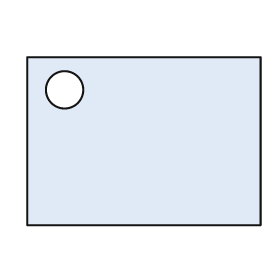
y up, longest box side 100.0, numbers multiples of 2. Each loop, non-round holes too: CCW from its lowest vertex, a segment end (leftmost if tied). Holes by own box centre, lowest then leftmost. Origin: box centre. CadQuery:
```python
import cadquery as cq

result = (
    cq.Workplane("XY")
    .moveTo(-50.0, -36.0)
    .lineTo(50.0, -36.0)
    .lineTo(50.0, 36.0)
    .lineTo(-50.0, 36.0)
    .close()
    .moveTo(-34.0, 22.0)
    .circle(8.0)
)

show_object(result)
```